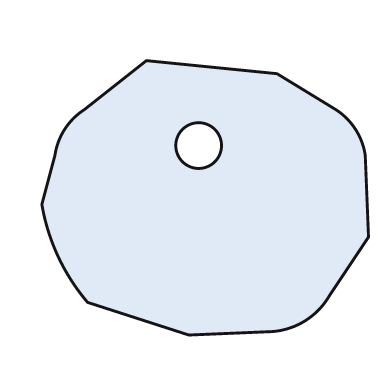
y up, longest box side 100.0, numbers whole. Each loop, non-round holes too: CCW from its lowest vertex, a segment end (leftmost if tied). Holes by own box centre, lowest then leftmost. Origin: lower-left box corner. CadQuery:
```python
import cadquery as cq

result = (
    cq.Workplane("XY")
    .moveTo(45.0, 0.0)
    .lineTo(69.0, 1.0)
    .threePointArc((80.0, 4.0), (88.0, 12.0))
    .lineTo(100.0, 30.0)
    .lineTo(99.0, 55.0)
    .threePointArc((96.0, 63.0), (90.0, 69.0))
    .lineTo(72.0, 80.0)
    .lineTo(32.0, 84.0)
    .lineTo(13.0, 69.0)
    .threePointArc((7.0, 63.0), (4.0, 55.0))
    .lineTo(0.0, 40.0)
    .threePointArc((5.0, 24.0), (14.0, 10.0))
    .close()
    .moveTo(48.0, 58.0)
    .circle(7.0)
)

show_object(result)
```